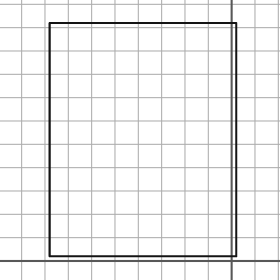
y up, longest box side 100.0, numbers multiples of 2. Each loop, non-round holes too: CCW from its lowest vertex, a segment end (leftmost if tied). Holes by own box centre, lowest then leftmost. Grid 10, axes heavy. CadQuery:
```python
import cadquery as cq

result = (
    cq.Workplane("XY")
    .moveTo(-78.0, 2.0)
    .lineTo(2.0, 2.0)
    .lineTo(2.0, 102.0)
    .lineTo(-78.0, 102.0)
    .close()
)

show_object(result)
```